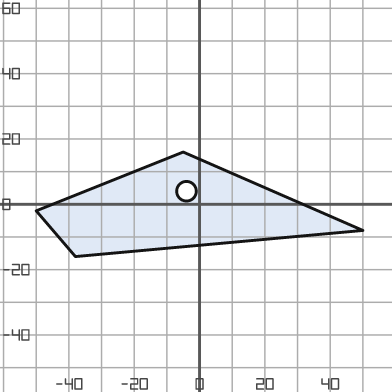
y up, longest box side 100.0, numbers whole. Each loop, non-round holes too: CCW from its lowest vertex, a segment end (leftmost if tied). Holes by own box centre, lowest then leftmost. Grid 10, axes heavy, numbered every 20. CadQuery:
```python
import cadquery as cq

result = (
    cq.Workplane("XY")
    .moveTo(-38.0, -16.0)
    .lineTo(50.0, -8.0)
    .lineTo(-5.0, 16.0)
    .lineTo(-50.0, -2.0)
    .close()
    .moveTo(-4.0, 4.0)
    .circle(3.0)
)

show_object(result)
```